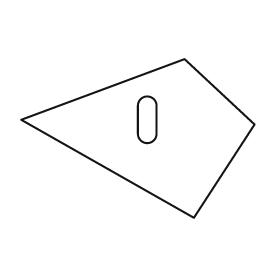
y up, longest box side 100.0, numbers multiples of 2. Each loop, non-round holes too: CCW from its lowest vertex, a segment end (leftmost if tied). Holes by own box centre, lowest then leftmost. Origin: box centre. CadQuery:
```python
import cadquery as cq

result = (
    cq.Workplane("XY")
    .moveTo(24.0, -34.0)
    .lineTo(50.0, 6.0)
    .lineTo(20.0, 34.0)
    .lineTo(-50.0, 8.0)
    .close()
    .moveTo(0.0, 2.0)
    .threePointArc((4.0, -2.0), (8.0, 2.0))
    .lineTo(8.0, 14.0)
    .threePointArc((4.0, 18.0), (0.0, 14.0))
    .close()
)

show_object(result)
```